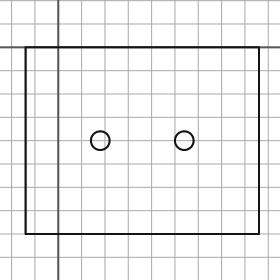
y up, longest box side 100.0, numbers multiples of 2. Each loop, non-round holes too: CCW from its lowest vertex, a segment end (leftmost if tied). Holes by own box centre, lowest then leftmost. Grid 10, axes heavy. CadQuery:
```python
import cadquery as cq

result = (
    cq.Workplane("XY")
    .moveTo(-14.0, -80.0)
    .lineTo(86.0, -80.0)
    .lineTo(86.0, 0.0)
    .lineTo(-14.0, 0.0)
    .close()
    .moveTo(18.0, -40.0)
    .circle(4.0)
    .moveTo(54.0, -40.0)
    .circle(4.0)
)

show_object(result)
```